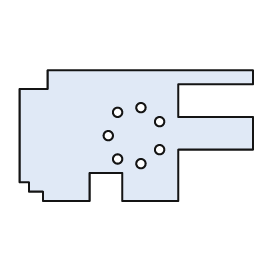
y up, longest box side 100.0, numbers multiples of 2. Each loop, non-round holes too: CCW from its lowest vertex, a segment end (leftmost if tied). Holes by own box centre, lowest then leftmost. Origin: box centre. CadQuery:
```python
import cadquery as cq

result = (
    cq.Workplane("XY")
    .moveTo(-40.0, -28.0)
    .lineTo(-20.0, -28.0)
    .lineTo(-20.0, -16.0)
    .lineTo(-6.0, -16.0)
    .lineTo(-6.0, -28.0)
    .lineTo(18.0, -28.0)
    .lineTo(18.0, -6.0)
    .lineTo(50.0, -6.0)
    .lineTo(50.0, 8.0)
    .lineTo(18.0, 8.0)
    .lineTo(18.0, 22.0)
    .lineTo(50.0, 22.0)
    .lineTo(50.0, 28.0)
    .lineTo(-38.0, 28.0)
    .lineTo(-38.0, 20.0)
    .lineTo(-50.0, 20.0)
    .lineTo(-50.0, -20.0)
    .lineTo(-46.0, -20.0)
    .lineTo(-46.0, -24.0)
    .lineTo(-40.0, -24.0)
    .close()
    .moveTo(2.0, -12.0)
    .circle(2.0)
    .moveTo(-8.0, -10.0)
    .circle(2.0)
    .moveTo(10.0, -6.0)
    .circle(2.0)
    .moveTo(-12.0, 0.0)
    .circle(2.0)
    .moveTo(10.0, 6.0)
    .circle(2.0)
    .moveTo(-8.0, 10.0)
    .circle(2.0)
    .moveTo(2.0, 12.0)
    .circle(2.0)
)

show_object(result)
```